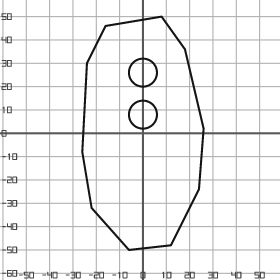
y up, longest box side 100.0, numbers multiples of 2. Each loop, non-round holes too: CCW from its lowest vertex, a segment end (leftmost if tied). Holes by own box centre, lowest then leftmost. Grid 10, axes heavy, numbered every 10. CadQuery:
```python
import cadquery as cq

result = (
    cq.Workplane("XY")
    .moveTo(-6.0, -50.0)
    .lineTo(12.0, -48.0)
    .lineTo(24.0, -24.0)
    .lineTo(26.0, 2.0)
    .lineTo(18.0, 36.0)
    .lineTo(8.0, 50.0)
    .lineTo(-16.0, 46.0)
    .lineTo(-24.0, 30.0)
    .lineTo(-26.0, -8.0)
    .lineTo(-22.0, -32.0)
    .close()
    .moveTo(0.0, 8.0)
    .circle(6.0)
    .moveTo(0.0, 26.0)
    .circle(6.0)
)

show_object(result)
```